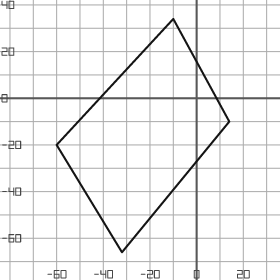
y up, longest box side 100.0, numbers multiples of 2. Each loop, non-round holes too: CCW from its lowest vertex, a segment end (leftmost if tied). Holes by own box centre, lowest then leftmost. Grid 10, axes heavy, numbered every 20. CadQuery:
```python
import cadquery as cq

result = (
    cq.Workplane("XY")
    .moveTo(-32.0, -66.0)
    .lineTo(14.0, -10.0)
    .lineTo(-10.0, 34.0)
    .lineTo(-60.0, -20.0)
    .close()
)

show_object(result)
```